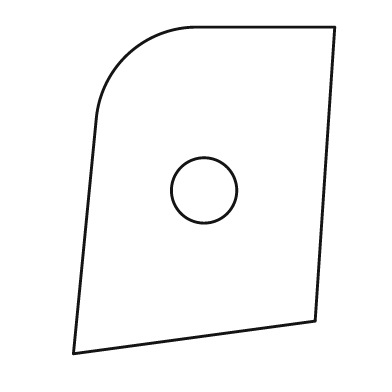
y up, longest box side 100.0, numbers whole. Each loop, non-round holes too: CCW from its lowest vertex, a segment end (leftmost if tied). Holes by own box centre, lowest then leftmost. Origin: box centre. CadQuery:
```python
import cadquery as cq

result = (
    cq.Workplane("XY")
    .moveTo(-40.0, -50.0)
    .lineTo(34.0, -40.0)
    .lineTo(40.0, 50.0)
    .lineTo(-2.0, 50.0)
    .threePointArc((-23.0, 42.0), (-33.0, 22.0))
    .close()
    .moveTo(0.0, 0.0)
    .circle(10.0)
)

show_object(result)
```